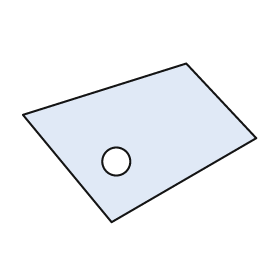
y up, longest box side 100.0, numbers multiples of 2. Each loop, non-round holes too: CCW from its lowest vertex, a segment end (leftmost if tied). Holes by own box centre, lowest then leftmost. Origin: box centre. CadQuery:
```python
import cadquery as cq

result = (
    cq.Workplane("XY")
    .moveTo(-12.0, -34.0)
    .lineTo(50.0, 2.0)
    .lineTo(20.0, 34.0)
    .lineTo(-50.0, 12.0)
    .close()
    .moveTo(-10.0, -8.0)
    .circle(6.0)
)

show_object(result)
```